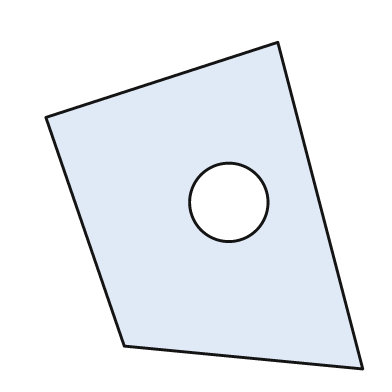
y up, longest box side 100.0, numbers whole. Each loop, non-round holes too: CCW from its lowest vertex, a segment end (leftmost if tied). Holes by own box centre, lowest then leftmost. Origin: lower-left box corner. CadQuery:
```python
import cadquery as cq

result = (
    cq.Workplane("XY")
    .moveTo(97.0, 0.0)
    .lineTo(71.0, 100.0)
    .lineTo(0.0, 77.0)
    .lineTo(24.0, 7.0)
    .close()
    .moveTo(56.0, 51.0)
    .circle(12.0)
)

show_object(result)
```